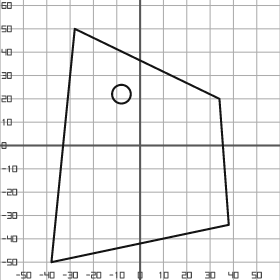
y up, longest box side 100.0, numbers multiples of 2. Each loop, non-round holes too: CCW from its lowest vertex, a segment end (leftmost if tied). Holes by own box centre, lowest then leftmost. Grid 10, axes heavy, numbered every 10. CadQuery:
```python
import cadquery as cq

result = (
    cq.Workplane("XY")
    .moveTo(-38.0, -50.0)
    .lineTo(38.0, -34.0)
    .lineTo(34.0, 20.0)
    .lineTo(-28.0, 50.0)
    .close()
    .moveTo(-8.0, 22.0)
    .circle(4.0)
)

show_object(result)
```